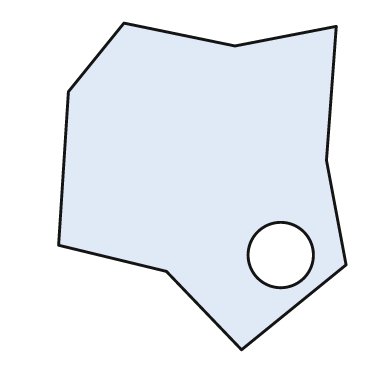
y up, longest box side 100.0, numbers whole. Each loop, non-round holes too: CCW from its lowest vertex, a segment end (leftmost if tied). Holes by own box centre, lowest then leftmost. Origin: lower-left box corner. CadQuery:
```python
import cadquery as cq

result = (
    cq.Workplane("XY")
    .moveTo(56.0, 0.0)
    .lineTo(88.0, 26.0)
    .lineTo(82.0, 58.0)
    .lineTo(85.0, 99.0)
    .lineTo(54.0, 93.0)
    .lineTo(20.0, 100.0)
    .lineTo(3.0, 79.0)
    .lineTo(0.0, 32.0)
    .lineTo(33.0, 24.0)
    .close()
    .moveTo(68.0, 29.0)
    .circle(10.0)
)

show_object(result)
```